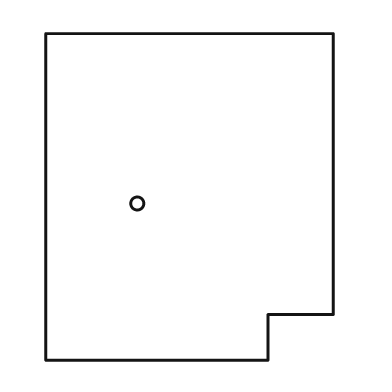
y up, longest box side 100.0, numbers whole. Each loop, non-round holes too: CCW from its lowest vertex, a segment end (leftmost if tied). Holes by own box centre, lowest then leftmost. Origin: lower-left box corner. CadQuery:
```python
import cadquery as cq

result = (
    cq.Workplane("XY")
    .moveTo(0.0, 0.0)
    .lineTo(68.0, 0.0)
    .lineTo(68.0, 14.0)
    .lineTo(88.0, 14.0)
    .lineTo(88.0, 100.0)
    .lineTo(0.0, 100.0)
    .close()
    .moveTo(28.0, 48.0)
    .circle(2.0)
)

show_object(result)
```